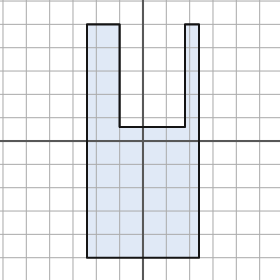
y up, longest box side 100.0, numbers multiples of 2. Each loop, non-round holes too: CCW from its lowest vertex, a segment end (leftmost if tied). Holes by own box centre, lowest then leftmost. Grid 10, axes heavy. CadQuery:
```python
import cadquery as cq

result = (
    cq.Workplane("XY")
    .moveTo(-24.0, -50.0)
    .lineTo(24.0, -50.0)
    .lineTo(24.0, 50.0)
    .lineTo(18.0, 50.0)
    .lineTo(18.0, 6.0)
    .lineTo(-10.0, 6.0)
    .lineTo(-10.0, 50.0)
    .lineTo(-24.0, 50.0)
    .close()
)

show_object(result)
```